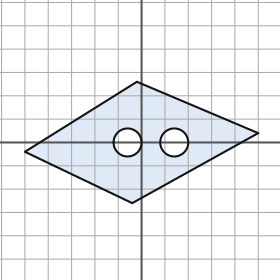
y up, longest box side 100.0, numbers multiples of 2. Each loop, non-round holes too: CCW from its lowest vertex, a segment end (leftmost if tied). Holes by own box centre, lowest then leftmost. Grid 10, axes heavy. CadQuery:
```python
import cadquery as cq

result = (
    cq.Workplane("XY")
    .moveTo(-4.0, -26.0)
    .lineTo(50.0, 4.0)
    .lineTo(-2.0, 26.0)
    .lineTo(-50.0, -4.0)
    .close()
    .moveTo(-6.0, 0.0)
    .circle(6.0)
    .moveTo(14.0, 0.0)
    .circle(6.0)
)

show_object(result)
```